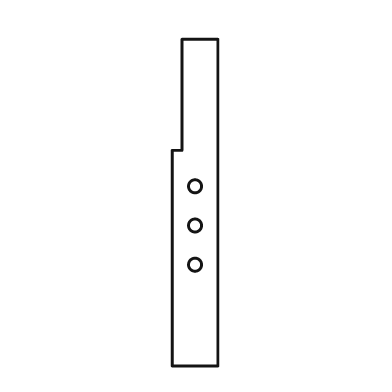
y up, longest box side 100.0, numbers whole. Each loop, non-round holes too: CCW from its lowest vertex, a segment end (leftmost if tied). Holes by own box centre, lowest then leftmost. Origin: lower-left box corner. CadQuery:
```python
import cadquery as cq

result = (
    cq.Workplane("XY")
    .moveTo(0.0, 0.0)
    .lineTo(14.0, 0.0)
    .lineTo(14.0, 100.0)
    .lineTo(3.0, 100.0)
    .lineTo(3.0, 66.0)
    .lineTo(0.0, 66.0)
    .close()
    .moveTo(7.0, 31.0)
    .circle(2.0)
    .moveTo(7.0, 43.0)
    .circle(2.0)
    .moveTo(7.0, 55.0)
    .circle(2.0)
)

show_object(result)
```